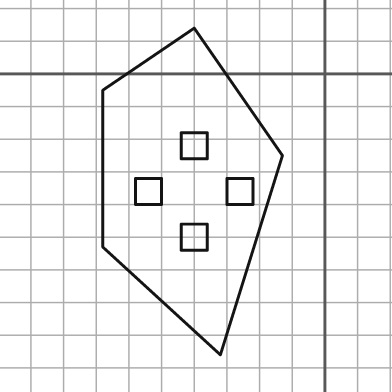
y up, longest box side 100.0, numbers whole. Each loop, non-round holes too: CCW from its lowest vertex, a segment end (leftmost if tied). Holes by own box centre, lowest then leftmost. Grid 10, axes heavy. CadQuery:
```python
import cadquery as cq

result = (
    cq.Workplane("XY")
    .moveTo(-32.0, -86.0)
    .lineTo(-13.0, -25.0)
    .lineTo(-40.0, 14.0)
    .lineTo(-68.0, -5.0)
    .lineTo(-68.0, -53.0)
    .close()
    .moveTo(-44.0, -54.0)
    .lineTo(-36.0, -54.0)
    .lineTo(-36.0, -46.0)
    .lineTo(-44.0, -46.0)
    .close()
    .moveTo(-58.0, -40.0)
    .lineTo(-50.0, -40.0)
    .lineTo(-50.0, -32.0)
    .lineTo(-58.0, -32.0)
    .close()
    .moveTo(-30.0, -40.0)
    .lineTo(-22.0, -40.0)
    .lineTo(-22.0, -32.0)
    .lineTo(-30.0, -32.0)
    .close()
    .moveTo(-44.0, -26.0)
    .lineTo(-36.0, -26.0)
    .lineTo(-36.0, -18.0)
    .lineTo(-44.0, -18.0)
    .close()
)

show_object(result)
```